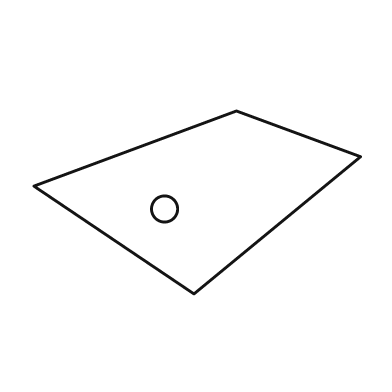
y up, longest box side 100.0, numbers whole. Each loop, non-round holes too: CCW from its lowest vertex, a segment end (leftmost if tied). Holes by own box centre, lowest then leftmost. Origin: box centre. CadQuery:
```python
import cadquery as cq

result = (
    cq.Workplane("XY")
    .moveTo(-1.0, -28.0)
    .lineTo(50.0, 14.0)
    .lineTo(12.0, 28.0)
    .lineTo(-50.0, 5.0)
    .close()
    .moveTo(-10.0, -2.0)
    .circle(4.0)
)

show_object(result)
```